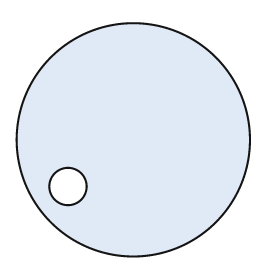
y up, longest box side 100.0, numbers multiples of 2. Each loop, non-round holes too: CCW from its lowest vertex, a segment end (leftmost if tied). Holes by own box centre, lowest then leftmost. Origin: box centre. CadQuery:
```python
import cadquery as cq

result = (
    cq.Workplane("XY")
    .moveTo(0.0, 0.0)
    .circle(50.0)
    .moveTo(-28.0, -20.0)
    .circle(8.0)
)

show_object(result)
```